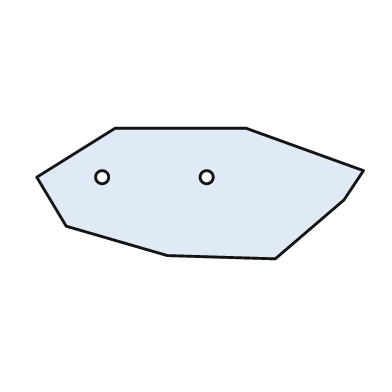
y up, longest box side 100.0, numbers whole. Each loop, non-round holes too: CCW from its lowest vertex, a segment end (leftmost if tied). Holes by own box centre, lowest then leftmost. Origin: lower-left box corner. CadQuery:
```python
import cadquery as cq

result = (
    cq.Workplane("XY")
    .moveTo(73.0, 0.0)
    .lineTo(94.0, 18.0)
    .lineTo(100.0, 27.0)
    .lineTo(64.0, 40.0)
    .lineTo(24.0, 40.0)
    .lineTo(0.0, 25.0)
    .lineTo(9.0, 10.0)
    .lineTo(40.0, 1.0)
    .close()
    .moveTo(20.0, 25.0)
    .circle(2.0)
    .moveTo(52.0, 25.0)
    .circle(2.0)
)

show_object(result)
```